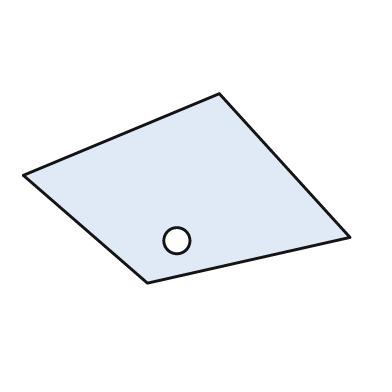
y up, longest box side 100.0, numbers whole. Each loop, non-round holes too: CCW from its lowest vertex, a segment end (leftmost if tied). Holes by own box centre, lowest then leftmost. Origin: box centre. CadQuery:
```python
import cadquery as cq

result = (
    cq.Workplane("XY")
    .moveTo(-12.0, -29.0)
    .lineTo(50.0, -15.0)
    .lineTo(10.0, 29.0)
    .lineTo(-50.0, 4.0)
    .close()
    .moveTo(-3.0, -16.0)
    .circle(4.0)
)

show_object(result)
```